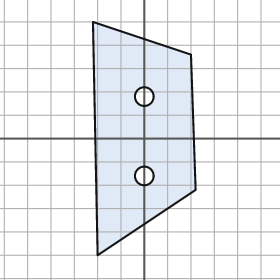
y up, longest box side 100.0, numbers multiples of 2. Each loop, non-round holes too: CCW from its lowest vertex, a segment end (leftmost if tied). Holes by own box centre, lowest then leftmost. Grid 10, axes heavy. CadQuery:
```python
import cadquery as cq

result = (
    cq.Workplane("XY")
    .moveTo(-20.0, -50.0)
    .lineTo(22.0, -22.0)
    .lineTo(20.0, 36.0)
    .lineTo(-22.0, 50.0)
    .close()
    .moveTo(0.0, -16.0)
    .circle(4.0)
    .moveTo(0.0, 18.0)
    .circle(4.0)
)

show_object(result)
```